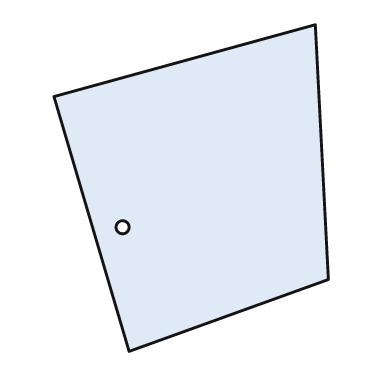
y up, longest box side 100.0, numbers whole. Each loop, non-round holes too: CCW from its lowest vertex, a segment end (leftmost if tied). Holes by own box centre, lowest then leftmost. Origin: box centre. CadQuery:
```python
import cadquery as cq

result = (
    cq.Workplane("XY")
    .moveTo(-19.0, -50.0)
    .lineTo(42.0, -28.0)
    .lineTo(38.0, 50.0)
    .lineTo(-42.0, 28.0)
    .close()
    .moveTo(-21.0, -12.0)
    .circle(2.0)
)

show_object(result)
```